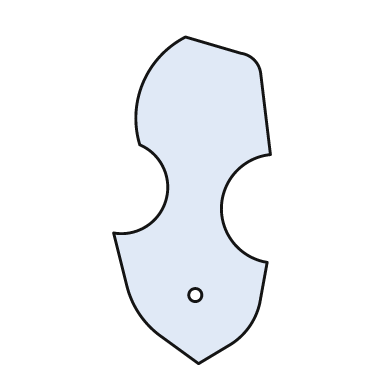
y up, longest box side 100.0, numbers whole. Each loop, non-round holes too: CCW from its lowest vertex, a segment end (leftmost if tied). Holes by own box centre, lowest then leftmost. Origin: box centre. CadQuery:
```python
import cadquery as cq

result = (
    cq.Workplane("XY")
    .moveTo(2.0, -50.0)
    .lineTo(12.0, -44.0)
    .threePointArc((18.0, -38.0), (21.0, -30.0))
    .lineTo(23.0, -19.0)
    .threePointArc((9.0, -2.0), (24.0, 14.0))
    .lineTo(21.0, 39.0)
    .threePointArc((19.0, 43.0), (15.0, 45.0))
    .lineTo(-2.0, 50.0)
    .threePointArc((-15.0, 36.0), (-16.0, 17.0))
    .threePointArc((-8.0, 0.0), (-24.0, -10.0))
    .lineTo(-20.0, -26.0)
    .threePointArc((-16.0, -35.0), (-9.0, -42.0))
    .close()
    .moveTo(1.0, -29.0)
    .circle(2.0)
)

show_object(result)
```